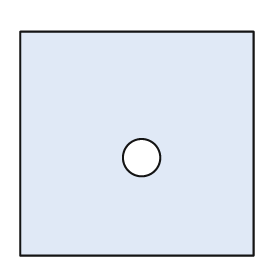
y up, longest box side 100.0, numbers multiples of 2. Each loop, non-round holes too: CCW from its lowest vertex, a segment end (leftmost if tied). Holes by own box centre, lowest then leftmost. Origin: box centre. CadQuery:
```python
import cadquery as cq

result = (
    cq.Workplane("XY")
    .moveTo(-50.0, -48.0)
    .lineTo(50.0, -48.0)
    .lineTo(50.0, 48.0)
    .lineTo(-50.0, 48.0)
    .close()
    .moveTo(2.0, -6.0)
    .circle(8.0)
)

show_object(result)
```